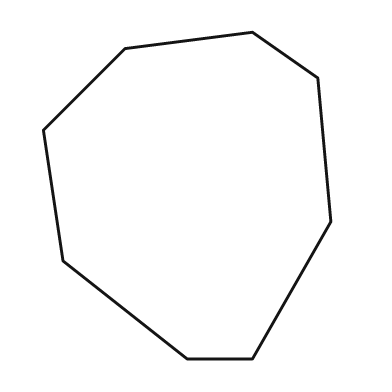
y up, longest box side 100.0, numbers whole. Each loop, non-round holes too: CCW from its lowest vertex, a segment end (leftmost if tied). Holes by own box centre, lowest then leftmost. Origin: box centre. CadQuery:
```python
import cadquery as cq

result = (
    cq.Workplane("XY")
    .moveTo(0.0, -50.0)
    .lineTo(20.0, -50.0)
    .lineTo(44.0, -8.0)
    .lineTo(40.0, 36.0)
    .lineTo(20.0, 50.0)
    .lineTo(-19.0, 45.0)
    .lineTo(-44.0, 20.0)
    .lineTo(-38.0, -20.0)
    .close()
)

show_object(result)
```